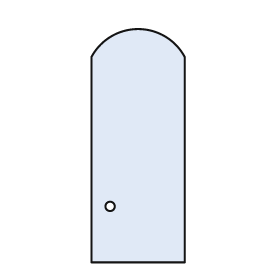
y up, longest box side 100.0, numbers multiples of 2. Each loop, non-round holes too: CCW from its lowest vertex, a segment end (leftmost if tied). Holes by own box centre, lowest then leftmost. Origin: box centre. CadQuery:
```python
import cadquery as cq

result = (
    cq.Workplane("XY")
    .moveTo(-20.0, -50.0)
    .lineTo(20.0, -50.0)
    .lineTo(20.0, 38.0)
    .threePointArc((0.0, 50.0), (-20.0, 38.0))
    .close()
    .moveTo(-12.0, -26.0)
    .circle(2.0)
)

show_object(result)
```